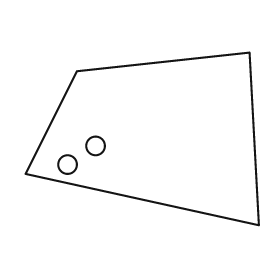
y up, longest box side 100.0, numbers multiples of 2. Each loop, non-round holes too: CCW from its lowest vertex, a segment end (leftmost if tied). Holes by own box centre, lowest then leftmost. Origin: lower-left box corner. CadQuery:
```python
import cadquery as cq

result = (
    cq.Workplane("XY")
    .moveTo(100.0, 0.0)
    .lineTo(96.0, 74.0)
    .lineTo(22.0, 66.0)
    .lineTo(0.0, 22.0)
    .close()
    .moveTo(18.0, 26.0)
    .circle(4.0)
    .moveTo(30.0, 34.0)
    .circle(4.0)
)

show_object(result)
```